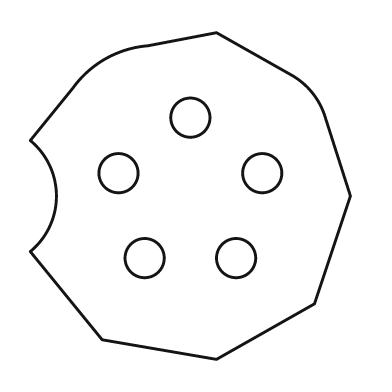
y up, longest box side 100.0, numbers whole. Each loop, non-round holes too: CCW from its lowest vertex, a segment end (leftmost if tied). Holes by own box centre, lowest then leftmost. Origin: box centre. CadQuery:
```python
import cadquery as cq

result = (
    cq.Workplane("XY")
    .moveTo(8.0, -50.0)
    .lineTo(38.0, -33.0)
    .lineTo(49.0, 0.0)
    .lineTo(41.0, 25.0)
    .threePointArc((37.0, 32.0), (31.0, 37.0))
    .lineTo(8.0, 50.0)
    .lineTo(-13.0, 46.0)
    .threePointArc((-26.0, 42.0), (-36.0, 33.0))
    .lineTo(-49.0, 17.0)
    .threePointArc((-41.0, 0.0), (-49.0, -17.0))
    .lineTo(-27.0, -44.0)
    .close()
    .moveTo(-14.0, -19.0)
    .circle(6.0)
    .moveTo(14.0, -19.0)
    .circle(6.0)
    .moveTo(-22.0, 7.0)
    .circle(6.0)
    .moveTo(22.0, 7.0)
    .circle(6.0)
    .moveTo(0.0, 24.0)
    .circle(6.0)
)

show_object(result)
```